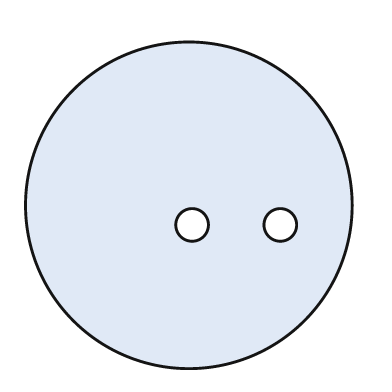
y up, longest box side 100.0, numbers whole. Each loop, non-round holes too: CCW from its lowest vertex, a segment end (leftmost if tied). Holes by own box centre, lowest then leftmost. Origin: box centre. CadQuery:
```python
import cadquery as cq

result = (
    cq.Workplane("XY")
    .moveTo(0.0, 0.0)
    .circle(50.0)
    .moveTo(1.0, -6.0)
    .circle(5.0)
    .moveTo(28.0, -6.0)
    .circle(5.0)
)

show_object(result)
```